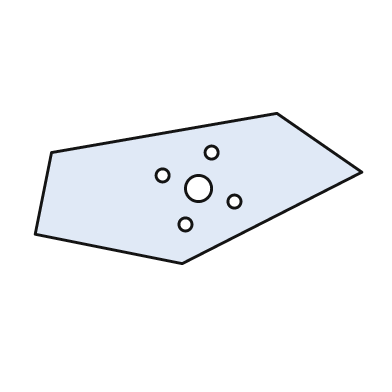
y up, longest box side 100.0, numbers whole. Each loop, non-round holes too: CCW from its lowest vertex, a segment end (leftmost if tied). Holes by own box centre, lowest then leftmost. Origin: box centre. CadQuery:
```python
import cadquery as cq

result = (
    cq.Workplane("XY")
    .moveTo(-5.0, -23.0)
    .lineTo(50.0, 5.0)
    .lineTo(24.0, 23.0)
    .lineTo(-45.0, 11.0)
    .lineTo(-50.0, -14.0)
    .close()
    .moveTo(-4.0, -11.0)
    .circle(2.0)
    .moveTo(11.0, -4.0)
    .circle(2.0)
    .moveTo(0.0, 0.0)
    .circle(4.0)
    .moveTo(-11.0, 4.0)
    .circle(2.0)
    .moveTo(4.0, 11.0)
    .circle(2.0)
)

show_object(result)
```